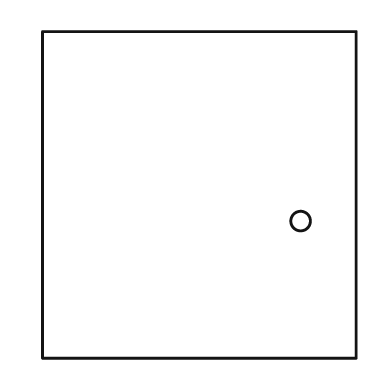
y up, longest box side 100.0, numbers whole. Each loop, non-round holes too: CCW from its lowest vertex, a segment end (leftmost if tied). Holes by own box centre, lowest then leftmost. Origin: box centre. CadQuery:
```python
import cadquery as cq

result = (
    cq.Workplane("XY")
    .moveTo(-48.0, -50.0)
    .lineTo(48.0, -50.0)
    .lineTo(48.0, 50.0)
    .lineTo(-48.0, 50.0)
    .close()
    .moveTo(31.0, -8.0)
    .circle(3.0)
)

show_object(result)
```